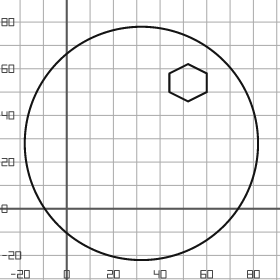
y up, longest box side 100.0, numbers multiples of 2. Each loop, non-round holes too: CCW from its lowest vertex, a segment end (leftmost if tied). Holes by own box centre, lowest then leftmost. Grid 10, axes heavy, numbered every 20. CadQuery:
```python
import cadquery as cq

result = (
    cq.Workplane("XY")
    .moveTo(32.0, 28.0)
    .circle(50.0)
    .moveTo(52.0, 46.0)
    .lineTo(60.0, 50.0)
    .lineTo(60.0, 58.0)
    .lineTo(52.0, 62.0)
    .lineTo(44.0, 58.0)
    .lineTo(44.0, 50.0)
    .close()
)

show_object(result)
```